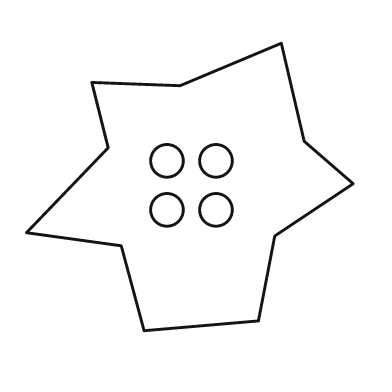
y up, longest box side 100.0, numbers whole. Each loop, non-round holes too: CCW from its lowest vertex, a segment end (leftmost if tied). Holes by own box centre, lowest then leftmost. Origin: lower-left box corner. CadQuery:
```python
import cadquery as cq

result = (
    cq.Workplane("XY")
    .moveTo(36.0, 0.0)
    .lineTo(71.0, 3.0)
    .lineTo(76.0, 29.0)
    .lineTo(100.0, 45.0)
    .lineTo(85.0, 58.0)
    .lineTo(78.0, 88.0)
    .lineTo(47.0, 75.0)
    .lineTo(20.0, 76.0)
    .lineTo(25.0, 56.0)
    .lineTo(0.0, 30.0)
    .lineTo(29.0, 26.0)
    .close()
    .moveTo(43.0, 37.0)
    .circle(5.0)
    .moveTo(58.0, 37.0)
    .circle(5.0)
    .moveTo(43.0, 52.0)
    .circle(5.0)
    .moveTo(58.0, 52.0)
    .circle(5.0)
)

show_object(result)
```